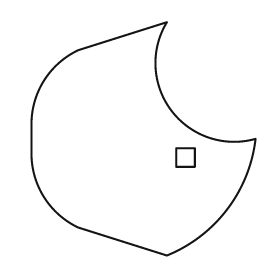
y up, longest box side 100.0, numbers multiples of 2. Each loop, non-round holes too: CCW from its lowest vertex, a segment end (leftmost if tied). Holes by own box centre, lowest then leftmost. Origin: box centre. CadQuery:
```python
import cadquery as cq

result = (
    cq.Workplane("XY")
    .moveTo(10.0, -50.0)
    .threePointArc((36.0, -30.0), (48.0, 0.0))
    .threePointArc((12.0, 12.0), (10.0, 50.0))
    .lineTo(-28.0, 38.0)
    .threePointArc((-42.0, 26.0), (-48.0, 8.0))
    .lineTo(-48.0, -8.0)
    .threePointArc((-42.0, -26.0), (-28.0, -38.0))
    .close()
    .moveTo(14.0, -12.0)
    .lineTo(22.0, -12.0)
    .lineTo(22.0, -4.0)
    .lineTo(14.0, -4.0)
    .close()
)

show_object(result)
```